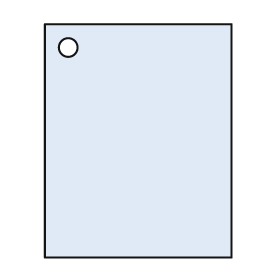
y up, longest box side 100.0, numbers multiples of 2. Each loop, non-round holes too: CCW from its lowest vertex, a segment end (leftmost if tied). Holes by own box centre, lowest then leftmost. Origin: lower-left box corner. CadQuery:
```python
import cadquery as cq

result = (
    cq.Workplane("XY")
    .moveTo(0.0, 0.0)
    .lineTo(80.0, 0.0)
    .lineTo(80.0, 100.0)
    .lineTo(0.0, 100.0)
    .close()
    .moveTo(10.0, 90.0)
    .circle(4.0)
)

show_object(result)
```